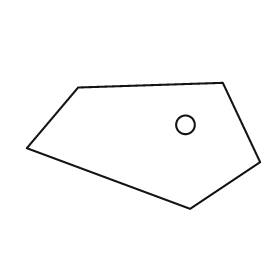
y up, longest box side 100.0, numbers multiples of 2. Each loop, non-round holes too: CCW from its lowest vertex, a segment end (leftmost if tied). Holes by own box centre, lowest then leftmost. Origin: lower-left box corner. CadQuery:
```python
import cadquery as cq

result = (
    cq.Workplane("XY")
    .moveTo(70.0, 0.0)
    .lineTo(100.0, 20.0)
    .lineTo(84.0, 54.0)
    .lineTo(22.0, 52.0)
    .lineTo(0.0, 26.0)
    .close()
    .moveTo(68.0, 36.0)
    .circle(4.0)
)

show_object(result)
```